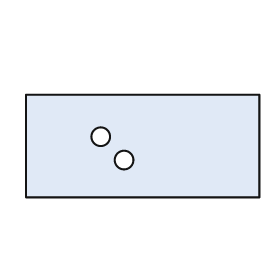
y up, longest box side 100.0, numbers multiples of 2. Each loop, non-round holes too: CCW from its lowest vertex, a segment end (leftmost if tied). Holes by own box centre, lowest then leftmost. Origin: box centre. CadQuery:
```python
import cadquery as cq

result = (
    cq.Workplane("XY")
    .moveTo(-50.0, -22.0)
    .lineTo(50.0, -22.0)
    .lineTo(50.0, 22.0)
    .lineTo(-50.0, 22.0)
    .close()
    .moveTo(-8.0, -6.0)
    .circle(4.0)
    .moveTo(-18.0, 4.0)
    .circle(4.0)
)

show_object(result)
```